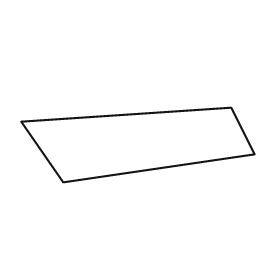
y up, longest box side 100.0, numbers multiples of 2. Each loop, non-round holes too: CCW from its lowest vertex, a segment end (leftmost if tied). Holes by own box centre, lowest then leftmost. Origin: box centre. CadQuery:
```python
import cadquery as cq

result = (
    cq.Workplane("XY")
    .moveTo(-32.0, -16.0)
    .lineTo(50.0, -4.0)
    .lineTo(40.0, 16.0)
    .lineTo(-50.0, 10.0)
    .close()
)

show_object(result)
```